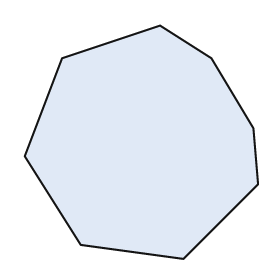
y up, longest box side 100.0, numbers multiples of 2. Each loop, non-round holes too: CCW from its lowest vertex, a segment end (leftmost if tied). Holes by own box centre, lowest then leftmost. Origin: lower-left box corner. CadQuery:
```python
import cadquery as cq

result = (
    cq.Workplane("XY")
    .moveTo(68.0, 0.0)
    .lineTo(100.0, 32.0)
    .lineTo(98.0, 56.0)
    .lineTo(80.0, 86.0)
    .lineTo(58.0, 100.0)
    .lineTo(16.0, 86.0)
    .lineTo(0.0, 44.0)
    .lineTo(24.0, 6.0)
    .close()
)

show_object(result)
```